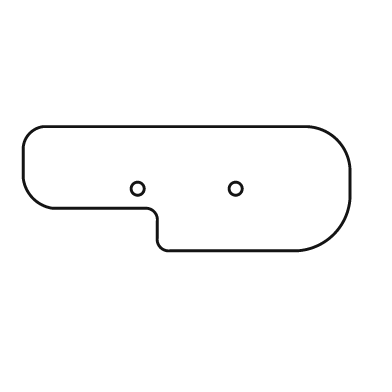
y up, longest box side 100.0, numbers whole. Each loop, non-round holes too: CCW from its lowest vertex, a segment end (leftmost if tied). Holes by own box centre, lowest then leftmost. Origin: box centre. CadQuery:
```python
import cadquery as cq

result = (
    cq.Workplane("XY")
    .moveTo(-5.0, -19.0)
    .lineTo(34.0, -19.0)
    .threePointArc((45.0, -14.0), (50.0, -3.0))
    .lineTo(50.0, 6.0)
    .threePointArc((46.0, 15.0), (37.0, 19.0))
    .lineTo(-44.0, 19.0)
    .threePointArc((-48.0, 17.0), (-50.0, 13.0))
    .lineTo(-50.0, 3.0)
    .threePointArc((-47.0, -3.0), (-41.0, -6.0))
    .lineTo(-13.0, -6.0)
    .threePointArc((-10.0, -7.0), (-9.0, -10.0))
    .lineTo(-9.0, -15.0)
    .threePointArc((-8.0, -18.0), (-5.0, -19.0))
    .close()
    .moveTo(-15.0, 0.0)
    .circle(2.0)
    .moveTo(15.0, 0.0)
    .circle(2.0)
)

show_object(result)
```